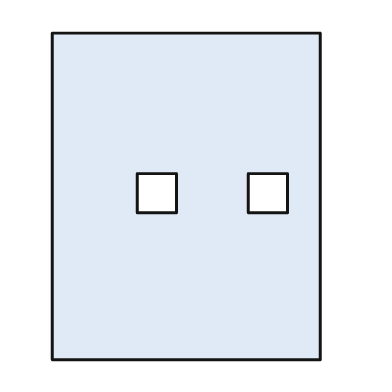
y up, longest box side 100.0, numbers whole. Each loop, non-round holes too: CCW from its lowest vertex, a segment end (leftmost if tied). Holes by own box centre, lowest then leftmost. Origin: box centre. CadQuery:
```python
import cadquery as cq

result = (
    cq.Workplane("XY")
    .moveTo(-41.0, -50.0)
    .lineTo(41.0, -50.0)
    .lineTo(41.0, 50.0)
    .lineTo(-41.0, 50.0)
    .close()
    .moveTo(-15.0, -5.0)
    .lineTo(-3.0, -5.0)
    .lineTo(-3.0, 7.0)
    .lineTo(-15.0, 7.0)
    .close()
    .moveTo(19.0, -5.0)
    .lineTo(31.0, -5.0)
    .lineTo(31.0, 7.0)
    .lineTo(19.0, 7.0)
    .close()
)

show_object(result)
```